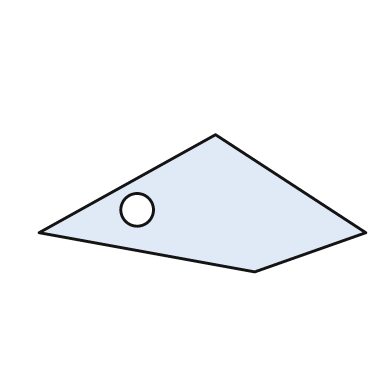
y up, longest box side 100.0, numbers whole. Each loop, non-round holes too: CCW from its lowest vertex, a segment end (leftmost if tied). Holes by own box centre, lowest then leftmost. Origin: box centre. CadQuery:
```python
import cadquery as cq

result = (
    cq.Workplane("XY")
    .moveTo(16.0, -21.0)
    .lineTo(50.0, -9.0)
    .lineTo(4.0, 21.0)
    .lineTo(-50.0, -9.0)
    .close()
    .moveTo(-20.0, -2.0)
    .circle(5.0)
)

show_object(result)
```